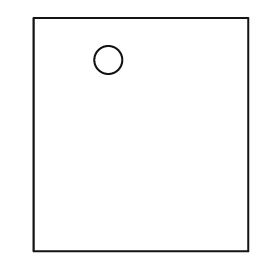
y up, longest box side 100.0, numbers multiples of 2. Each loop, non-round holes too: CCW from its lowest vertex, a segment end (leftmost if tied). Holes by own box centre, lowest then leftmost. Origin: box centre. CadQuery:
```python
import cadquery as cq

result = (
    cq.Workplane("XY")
    .moveTo(-46.0, -50.0)
    .lineTo(46.0, -50.0)
    .lineTo(46.0, 50.0)
    .lineTo(-46.0, 50.0)
    .close()
    .moveTo(-14.0, 32.0)
    .circle(6.0)
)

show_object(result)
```